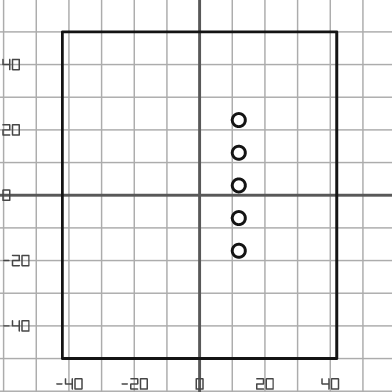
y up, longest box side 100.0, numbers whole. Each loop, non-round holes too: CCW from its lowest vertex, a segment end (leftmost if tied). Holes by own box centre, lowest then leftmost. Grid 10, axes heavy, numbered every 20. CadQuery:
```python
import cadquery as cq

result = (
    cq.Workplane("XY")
    .moveTo(-42.0, -50.0)
    .lineTo(42.0, -50.0)
    .lineTo(42.0, 50.0)
    .lineTo(-42.0, 50.0)
    .close()
    .moveTo(12.0, -17.0)
    .circle(2.0)
    .moveTo(12.0, -7.0)
    .circle(2.0)
    .moveTo(12.0, 3.0)
    .circle(2.0)
    .moveTo(12.0, 13.0)
    .circle(2.0)
    .moveTo(12.0, 23.0)
    .circle(2.0)
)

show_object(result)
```